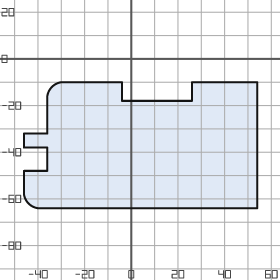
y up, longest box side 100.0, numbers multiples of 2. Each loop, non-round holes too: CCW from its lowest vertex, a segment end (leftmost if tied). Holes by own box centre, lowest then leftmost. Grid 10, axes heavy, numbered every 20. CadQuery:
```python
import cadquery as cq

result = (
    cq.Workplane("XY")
    .moveTo(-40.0, -64.0)
    .lineTo(54.0, -64.0)
    .lineTo(54.0, -10.0)
    .lineTo(26.0, -10.0)
    .lineTo(26.0, -18.0)
    .lineTo(-4.0, -18.0)
    .lineTo(-4.0, -10.0)
    .lineTo(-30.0, -10.0)
    .threePointArc((-34.0, -12.0), (-36.0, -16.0))
    .lineTo(-36.0, -32.0)
    .lineTo(-46.0, -32.0)
    .lineTo(-46.0, -38.0)
    .lineTo(-36.0, -38.0)
    .lineTo(-36.0, -48.0)
    .lineTo(-46.0, -48.0)
    .lineTo(-46.0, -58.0)
    .threePointArc((-44.0, -62.0), (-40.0, -64.0))
    .close()
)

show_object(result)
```